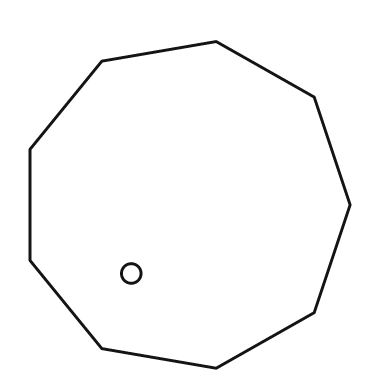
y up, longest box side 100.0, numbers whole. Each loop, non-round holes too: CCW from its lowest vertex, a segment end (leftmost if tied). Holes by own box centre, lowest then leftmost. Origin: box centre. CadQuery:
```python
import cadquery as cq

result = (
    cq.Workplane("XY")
    .moveTo(8.0, -50.0)
    .lineTo(38.0, -33.0)
    .lineTo(49.0, 0.0)
    .lineTo(38.0, 33.0)
    .lineTo(8.0, 50.0)
    .lineTo(-27.0, 44.0)
    .lineTo(-49.0, 17.0)
    .lineTo(-49.0, -17.0)
    .lineTo(-27.0, -44.0)
    .close()
    .moveTo(-18.0, -21.0)
    .circle(3.0)
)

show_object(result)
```